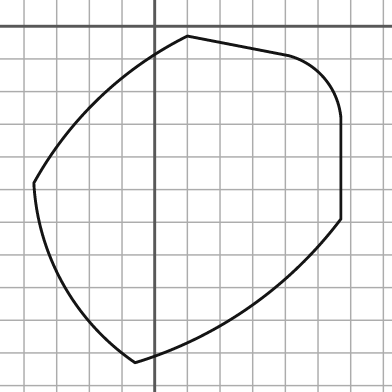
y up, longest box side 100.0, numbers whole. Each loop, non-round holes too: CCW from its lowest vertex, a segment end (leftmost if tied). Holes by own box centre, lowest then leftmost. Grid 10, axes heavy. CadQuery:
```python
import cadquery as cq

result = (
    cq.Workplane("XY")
    .moveTo(-6.0, -103.0)
    .threePointArc((29.0, -86.0), (57.0, -59.0))
    .lineTo(57.0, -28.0)
    .threePointArc((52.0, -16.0), (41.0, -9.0))
    .lineTo(10.0, -3.0)
    .threePointArc((-17.0, -22.0), (-37.0, -48.0))
    .threePointArc((-28.0, -79.0), (-6.0, -103.0))
    .close()
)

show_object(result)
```